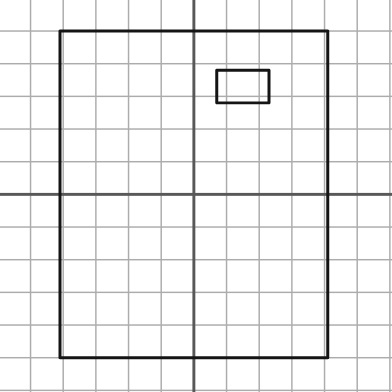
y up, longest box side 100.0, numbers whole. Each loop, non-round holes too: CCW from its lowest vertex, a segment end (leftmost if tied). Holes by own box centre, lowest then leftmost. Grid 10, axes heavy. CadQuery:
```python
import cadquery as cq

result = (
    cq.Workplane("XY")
    .moveTo(-41.0, -50.0)
    .lineTo(41.0, -50.0)
    .lineTo(41.0, 50.0)
    .lineTo(-41.0, 50.0)
    .close()
    .moveTo(7.0, 28.0)
    .lineTo(23.0, 28.0)
    .lineTo(23.0, 38.0)
    .lineTo(7.0, 38.0)
    .close()
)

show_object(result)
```